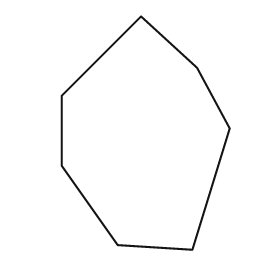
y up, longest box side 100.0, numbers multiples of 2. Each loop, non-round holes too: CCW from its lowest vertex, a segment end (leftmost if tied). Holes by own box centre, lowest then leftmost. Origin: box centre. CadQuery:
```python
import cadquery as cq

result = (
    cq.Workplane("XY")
    .moveTo(20.0, -50.0)
    .lineTo(36.0, 2.0)
    .lineTo(22.0, 28.0)
    .lineTo(-2.0, 50.0)
    .lineTo(-36.0, 16.0)
    .lineTo(-36.0, -14.0)
    .lineTo(-12.0, -48.0)
    .close()
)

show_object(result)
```